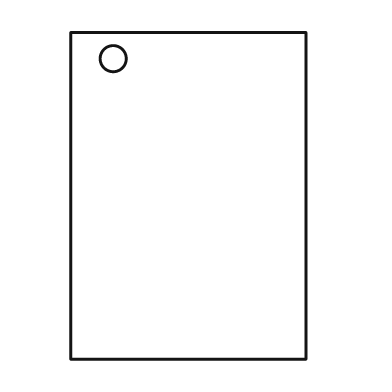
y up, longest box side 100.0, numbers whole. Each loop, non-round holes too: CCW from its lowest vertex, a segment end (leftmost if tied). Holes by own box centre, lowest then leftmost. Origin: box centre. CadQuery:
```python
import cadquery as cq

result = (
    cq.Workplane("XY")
    .moveTo(-36.0, -50.0)
    .lineTo(36.0, -50.0)
    .lineTo(36.0, 50.0)
    .lineTo(-36.0, 50.0)
    .close()
    .moveTo(-23.0, 42.0)
    .circle(4.0)
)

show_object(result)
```